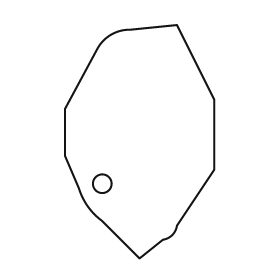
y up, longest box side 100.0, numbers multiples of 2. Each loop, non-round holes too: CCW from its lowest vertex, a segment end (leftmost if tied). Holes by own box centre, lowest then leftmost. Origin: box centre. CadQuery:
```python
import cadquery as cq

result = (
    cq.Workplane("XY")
    .moveTo(0.0, -50.0)
    .lineTo(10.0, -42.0)
    .threePointArc((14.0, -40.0), (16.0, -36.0))
    .lineTo(32.0, -12.0)
    .lineTo(32.0, 18.0)
    .lineTo(16.0, 50.0)
    .lineTo(-4.0, 48.0)
    .threePointArc((-12.0, 46.0), (-18.0, 40.0))
    .lineTo(-32.0, 14.0)
    .lineTo(-32.0, -6.0)
    .lineTo(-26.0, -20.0)
    .threePointArc((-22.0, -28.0), (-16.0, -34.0))
    .close()
    .moveTo(-16.0, -18.0)
    .circle(4.0)
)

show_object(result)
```